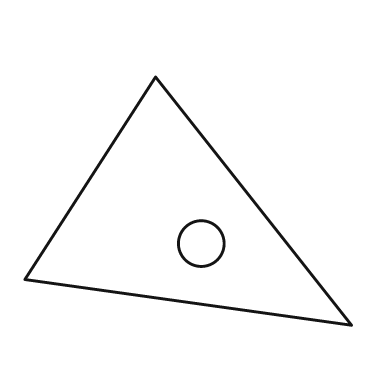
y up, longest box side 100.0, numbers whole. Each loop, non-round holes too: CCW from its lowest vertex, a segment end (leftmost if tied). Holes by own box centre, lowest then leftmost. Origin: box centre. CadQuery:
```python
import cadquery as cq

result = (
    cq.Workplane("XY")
    .moveTo(50.0, -38.0)
    .lineTo(-10.0, 38.0)
    .lineTo(-50.0, -24.0)
    .close()
    .moveTo(4.0, -13.0)
    .circle(7.0)
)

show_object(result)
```